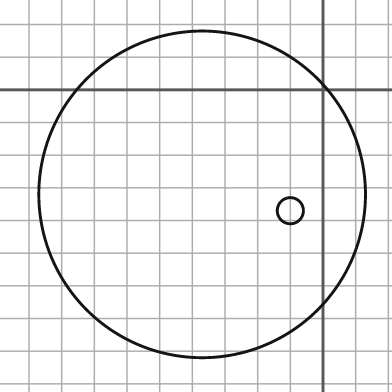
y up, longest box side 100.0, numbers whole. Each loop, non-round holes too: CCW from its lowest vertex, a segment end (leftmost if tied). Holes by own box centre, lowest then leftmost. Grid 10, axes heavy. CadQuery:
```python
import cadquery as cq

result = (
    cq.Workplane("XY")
    .moveTo(-37.0, -32.0)
    .circle(50.0)
    .moveTo(-10.0, -37.0)
    .circle(4.0)
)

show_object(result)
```